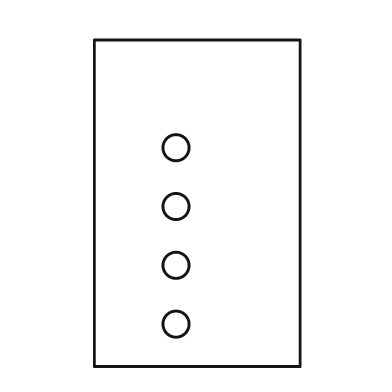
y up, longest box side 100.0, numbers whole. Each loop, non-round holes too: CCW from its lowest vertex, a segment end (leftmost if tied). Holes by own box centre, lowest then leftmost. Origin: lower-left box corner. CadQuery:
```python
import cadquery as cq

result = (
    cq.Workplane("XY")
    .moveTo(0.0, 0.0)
    .lineTo(63.0, 0.0)
    .lineTo(63.0, 100.0)
    .lineTo(0.0, 100.0)
    .close()
    .moveTo(25.0, 13.0)
    .circle(4.0)
    .moveTo(25.0, 31.0)
    .circle(4.0)
    .moveTo(25.0, 49.0)
    .circle(4.0)
    .moveTo(25.0, 67.0)
    .circle(4.0)
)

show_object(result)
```